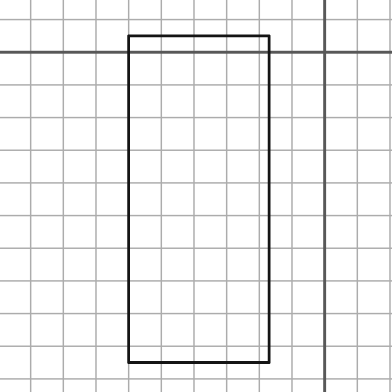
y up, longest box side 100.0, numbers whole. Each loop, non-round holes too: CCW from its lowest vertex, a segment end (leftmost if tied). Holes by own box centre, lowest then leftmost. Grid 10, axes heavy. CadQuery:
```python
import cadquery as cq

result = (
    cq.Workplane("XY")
    .moveTo(-60.0, -95.0)
    .lineTo(-17.0, -95.0)
    .lineTo(-17.0, 5.0)
    .lineTo(-60.0, 5.0)
    .close()
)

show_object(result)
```